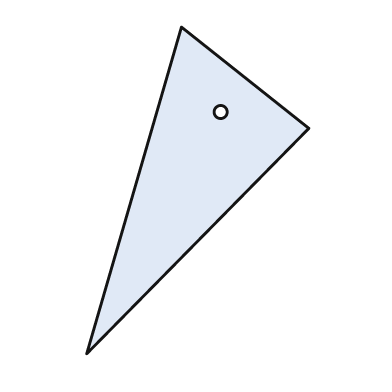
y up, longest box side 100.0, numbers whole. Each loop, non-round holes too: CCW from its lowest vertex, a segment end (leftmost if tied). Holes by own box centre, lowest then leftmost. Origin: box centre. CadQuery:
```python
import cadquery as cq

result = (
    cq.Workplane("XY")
    .moveTo(-34.0, -50.0)
    .lineTo(34.0, 19.0)
    .lineTo(-5.0, 50.0)
    .close()
    .moveTo(7.0, 24.0)
    .circle(2.0)
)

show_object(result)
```